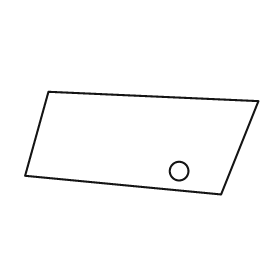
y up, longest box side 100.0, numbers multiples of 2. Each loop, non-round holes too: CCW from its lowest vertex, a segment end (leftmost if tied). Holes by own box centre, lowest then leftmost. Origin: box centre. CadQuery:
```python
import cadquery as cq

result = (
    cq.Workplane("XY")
    .moveTo(34.0, -22.0)
    .lineTo(50.0, 18.0)
    .lineTo(-40.0, 22.0)
    .lineTo(-50.0, -14.0)
    .close()
    .moveTo(16.0, -12.0)
    .circle(4.0)
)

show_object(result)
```